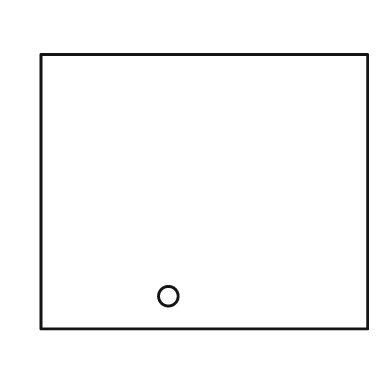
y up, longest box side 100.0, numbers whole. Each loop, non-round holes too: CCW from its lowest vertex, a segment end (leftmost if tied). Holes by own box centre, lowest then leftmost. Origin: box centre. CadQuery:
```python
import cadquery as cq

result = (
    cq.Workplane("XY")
    .moveTo(-50.0, -42.0)
    .lineTo(50.0, -42.0)
    .lineTo(50.0, 42.0)
    .lineTo(-50.0, 42.0)
    .close()
    .moveTo(-11.0, -32.0)
    .circle(3.0)
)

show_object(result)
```